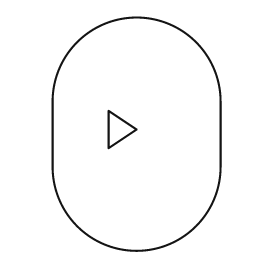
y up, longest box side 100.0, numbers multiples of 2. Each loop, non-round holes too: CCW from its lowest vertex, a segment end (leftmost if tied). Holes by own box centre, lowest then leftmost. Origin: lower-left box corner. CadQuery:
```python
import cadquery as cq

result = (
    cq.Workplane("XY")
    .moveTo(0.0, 36.0)
    .threePointArc((36.0, 0.0), (72.0, 36.0))
    .lineTo(72.0, 64.0)
    .threePointArc((36.0, 100.0), (0.0, 64.0))
    .close()
    .moveTo(24.0, 44.0)
    .lineTo(36.0, 52.0)
    .lineTo(24.0, 60.0)
    .close()
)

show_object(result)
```